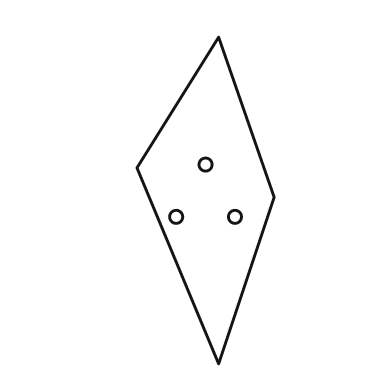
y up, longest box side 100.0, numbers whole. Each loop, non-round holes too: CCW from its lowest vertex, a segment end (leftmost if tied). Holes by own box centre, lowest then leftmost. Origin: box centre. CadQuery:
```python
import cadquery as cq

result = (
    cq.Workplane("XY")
    .moveTo(4.0, -50.0)
    .lineTo(21.0, 1.0)
    .lineTo(4.0, 50.0)
    .lineTo(-21.0, 10.0)
    .close()
    .moveTo(-9.0, -5.0)
    .circle(2.0)
    .moveTo(9.0, -5.0)
    .circle(2.0)
    .moveTo(0.0, 11.0)
    .circle(2.0)
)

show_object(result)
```